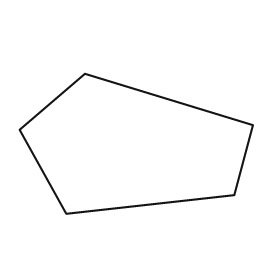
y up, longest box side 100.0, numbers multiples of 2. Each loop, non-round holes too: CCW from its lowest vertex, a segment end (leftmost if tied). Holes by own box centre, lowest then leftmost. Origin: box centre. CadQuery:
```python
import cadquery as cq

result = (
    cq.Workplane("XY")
    .moveTo(-30.0, -30.0)
    .lineTo(42.0, -22.0)
    .lineTo(50.0, 8.0)
    .lineTo(-22.0, 30.0)
    .lineTo(-50.0, 6.0)
    .close()
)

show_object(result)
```